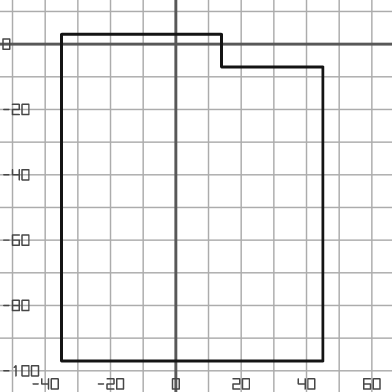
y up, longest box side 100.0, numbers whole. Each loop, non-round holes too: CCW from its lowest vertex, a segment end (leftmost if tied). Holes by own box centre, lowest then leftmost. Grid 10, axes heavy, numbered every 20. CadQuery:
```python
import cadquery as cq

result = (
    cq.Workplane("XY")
    .moveTo(-35.0, -97.0)
    .lineTo(45.0, -97.0)
    .lineTo(45.0, -7.0)
    .lineTo(14.0, -7.0)
    .lineTo(14.0, 3.0)
    .lineTo(-35.0, 3.0)
    .close()
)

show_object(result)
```